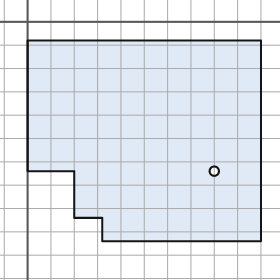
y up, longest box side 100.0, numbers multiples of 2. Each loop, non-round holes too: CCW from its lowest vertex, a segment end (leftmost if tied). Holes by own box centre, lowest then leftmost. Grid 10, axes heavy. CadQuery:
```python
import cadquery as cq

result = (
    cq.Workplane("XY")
    .moveTo(32.0, -94.0)
    .lineTo(100.0, -94.0)
    .lineTo(100.0, -8.0)
    .lineTo(0.0, -8.0)
    .lineTo(0.0, -64.0)
    .lineTo(20.0, -64.0)
    .lineTo(20.0, -84.0)
    .lineTo(32.0, -84.0)
    .close()
    .moveTo(80.0, -64.0)
    .circle(2.0)
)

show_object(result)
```